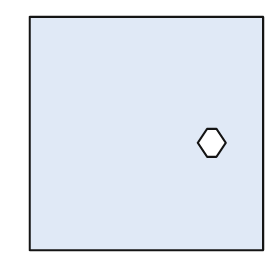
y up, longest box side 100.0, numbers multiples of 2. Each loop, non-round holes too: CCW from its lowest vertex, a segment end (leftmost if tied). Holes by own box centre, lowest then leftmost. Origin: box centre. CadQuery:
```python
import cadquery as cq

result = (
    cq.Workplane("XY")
    .moveTo(-50.0, -50.0)
    .lineTo(50.0, -50.0)
    .lineTo(50.0, 50.0)
    .lineTo(-50.0, 50.0)
    .close()
    .moveTo(26.0, -10.0)
    .lineTo(30.0, -10.0)
    .lineTo(34.0, -4.0)
    .lineTo(30.0, 2.0)
    .lineTo(26.0, 2.0)
    .lineTo(22.0, -4.0)
    .close()
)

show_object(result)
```